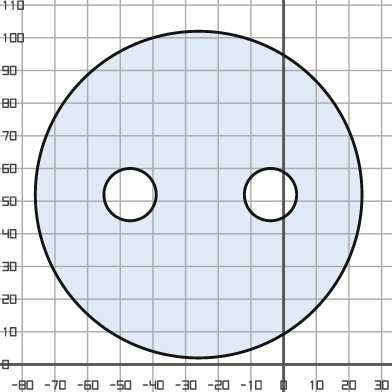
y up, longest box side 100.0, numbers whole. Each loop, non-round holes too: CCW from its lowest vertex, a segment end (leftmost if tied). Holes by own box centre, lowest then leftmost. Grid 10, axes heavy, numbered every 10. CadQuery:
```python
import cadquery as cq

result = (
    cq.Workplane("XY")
    .moveTo(-26.0, 52.0)
    .circle(50.0)
    .moveTo(-47.0, 52.0)
    .circle(8.0)
    .moveTo(-4.0, 52.0)
    .circle(8.0)
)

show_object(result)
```